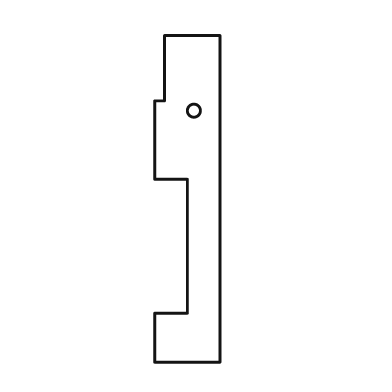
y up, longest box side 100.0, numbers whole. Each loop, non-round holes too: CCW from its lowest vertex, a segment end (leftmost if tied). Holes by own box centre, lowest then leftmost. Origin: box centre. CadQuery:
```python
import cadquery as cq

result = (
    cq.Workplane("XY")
    .moveTo(-10.0, -50.0)
    .lineTo(10.0, -50.0)
    .lineTo(10.0, 50.0)
    .lineTo(-7.0, 50.0)
    .lineTo(-7.0, 30.0)
    .lineTo(-10.0, 30.0)
    .lineTo(-10.0, 6.0)
    .lineTo(0.0, 6.0)
    .lineTo(0.0, -35.0)
    .lineTo(-10.0, -35.0)
    .close()
    .moveTo(2.0, 27.0)
    .circle(2.0)
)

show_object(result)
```